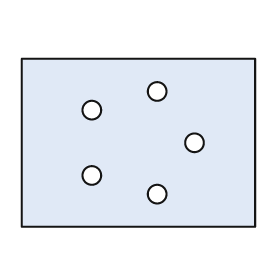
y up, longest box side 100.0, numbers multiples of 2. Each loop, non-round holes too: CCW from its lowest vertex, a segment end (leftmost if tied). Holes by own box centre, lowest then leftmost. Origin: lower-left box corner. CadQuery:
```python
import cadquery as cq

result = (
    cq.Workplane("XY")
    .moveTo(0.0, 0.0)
    .lineTo(100.0, 0.0)
    .lineTo(100.0, 72.0)
    .lineTo(0.0, 72.0)
    .close()
    .moveTo(58.0, 14.0)
    .circle(4.0)
    .moveTo(30.0, 22.0)
    .circle(4.0)
    .moveTo(74.0, 36.0)
    .circle(4.0)
    .moveTo(30.0, 50.0)
    .circle(4.0)
    .moveTo(58.0, 58.0)
    .circle(4.0)
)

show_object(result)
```